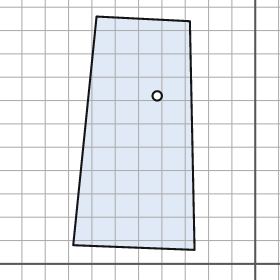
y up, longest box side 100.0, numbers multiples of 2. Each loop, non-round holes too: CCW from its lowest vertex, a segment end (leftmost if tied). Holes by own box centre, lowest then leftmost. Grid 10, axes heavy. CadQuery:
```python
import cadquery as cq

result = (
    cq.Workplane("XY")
    .moveTo(-26.0, 6.0)
    .lineTo(-28.0, 104.0)
    .lineTo(-68.0, 106.0)
    .lineTo(-78.0, 8.0)
    .close()
    .moveTo(-42.0, 72.0)
    .circle(2.0)
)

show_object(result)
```